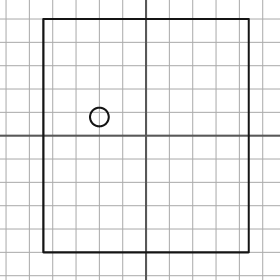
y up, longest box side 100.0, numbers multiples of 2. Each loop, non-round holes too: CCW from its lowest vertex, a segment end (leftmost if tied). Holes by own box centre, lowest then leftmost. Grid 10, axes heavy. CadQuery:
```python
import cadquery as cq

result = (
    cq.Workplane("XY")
    .moveTo(-44.0, -50.0)
    .lineTo(44.0, -50.0)
    .lineTo(44.0, 50.0)
    .lineTo(-44.0, 50.0)
    .close()
    .moveTo(-20.0, 8.0)
    .circle(4.0)
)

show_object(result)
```